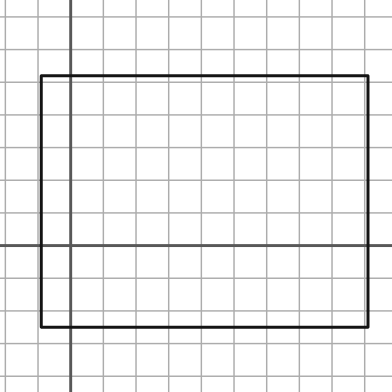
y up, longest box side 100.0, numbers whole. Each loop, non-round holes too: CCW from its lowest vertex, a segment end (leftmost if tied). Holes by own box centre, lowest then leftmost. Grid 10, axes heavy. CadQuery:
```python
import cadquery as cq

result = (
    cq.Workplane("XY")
    .moveTo(-9.0, -25.0)
    .lineTo(91.0, -25.0)
    .lineTo(91.0, 52.0)
    .lineTo(-9.0, 52.0)
    .close()
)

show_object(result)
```